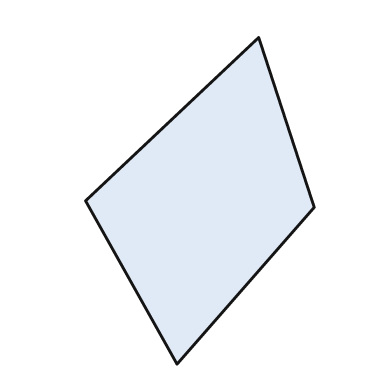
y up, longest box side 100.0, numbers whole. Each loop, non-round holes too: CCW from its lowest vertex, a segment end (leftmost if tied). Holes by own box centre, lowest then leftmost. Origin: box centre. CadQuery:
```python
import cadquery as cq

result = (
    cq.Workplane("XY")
    .moveTo(-7.0, -50.0)
    .lineTo(35.0, -2.0)
    .lineTo(18.0, 50.0)
    .lineTo(-35.0, 0.0)
    .close()
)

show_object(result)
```